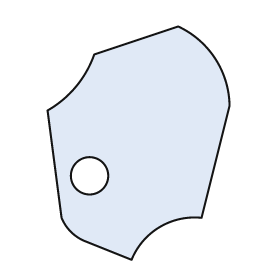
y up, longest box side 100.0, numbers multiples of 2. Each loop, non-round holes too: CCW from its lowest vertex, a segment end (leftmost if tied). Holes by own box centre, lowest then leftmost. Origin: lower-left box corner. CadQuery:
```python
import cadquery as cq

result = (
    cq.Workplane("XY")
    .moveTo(36.0, 0.0)
    .threePointArc((48.0, 14.0), (66.0, 18.0))
    .lineTo(78.0, 66.0)
    .threePointArc((72.0, 86.0), (56.0, 100.0))
    .lineTo(20.0, 88.0)
    .threePointArc((12.0, 74.0), (0.0, 64.0))
    .lineTo(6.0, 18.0)
    .threePointArc((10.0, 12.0), (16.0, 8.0))
    .close()
    .moveTo(18.0, 36.0)
    .circle(8.0)
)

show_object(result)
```